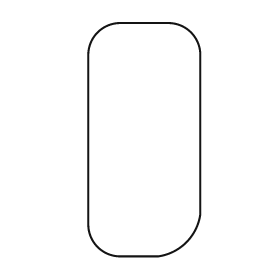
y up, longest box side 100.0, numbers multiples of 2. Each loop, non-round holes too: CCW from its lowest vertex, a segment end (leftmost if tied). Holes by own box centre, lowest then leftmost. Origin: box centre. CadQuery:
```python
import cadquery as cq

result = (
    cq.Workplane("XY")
    .moveTo(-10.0, -50.0)
    .lineTo(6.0, -50.0)
    .threePointArc((18.0, -44.0), (24.0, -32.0))
    .lineTo(24.0, 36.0)
    .threePointArc((20.0, 46.0), (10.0, 50.0))
    .lineTo(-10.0, 50.0)
    .threePointArc((-20.0, 46.0), (-24.0, 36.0))
    .lineTo(-24.0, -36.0)
    .threePointArc((-20.0, -46.0), (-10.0, -50.0))
    .close()
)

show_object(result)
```